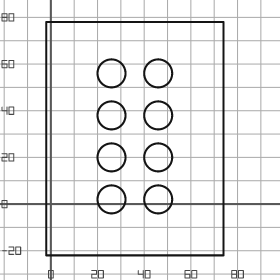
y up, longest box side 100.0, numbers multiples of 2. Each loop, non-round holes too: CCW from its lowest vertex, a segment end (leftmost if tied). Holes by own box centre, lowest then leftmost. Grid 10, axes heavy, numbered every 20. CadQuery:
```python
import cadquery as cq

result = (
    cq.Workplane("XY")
    .moveTo(-2.0, -22.0)
    .lineTo(74.0, -22.0)
    .lineTo(74.0, 78.0)
    .lineTo(-2.0, 78.0)
    .close()
    .moveTo(26.0, 2.0)
    .circle(6.0)
    .moveTo(46.0, 2.0)
    .circle(6.0)
    .moveTo(26.0, 20.0)
    .circle(6.0)
    .moveTo(46.0, 20.0)
    .circle(6.0)
    .moveTo(26.0, 38.0)
    .circle(6.0)
    .moveTo(46.0, 38.0)
    .circle(6.0)
    .moveTo(26.0, 56.0)
    .circle(6.0)
    .moveTo(46.0, 56.0)
    .circle(6.0)
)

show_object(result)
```